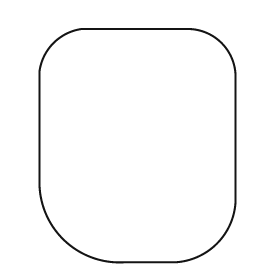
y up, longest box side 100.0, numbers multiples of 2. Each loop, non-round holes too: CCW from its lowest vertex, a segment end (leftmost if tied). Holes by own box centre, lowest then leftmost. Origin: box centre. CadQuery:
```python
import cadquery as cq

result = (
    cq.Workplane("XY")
    .moveTo(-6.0, -50.0)
    .lineTo(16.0, -50.0)
    .threePointArc((34.0, -42.0), (42.0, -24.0))
    .lineTo(42.0, 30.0)
    .threePointArc((36.0, 44.0), (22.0, 50.0))
    .lineTo(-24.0, 50.0)
    .threePointArc((-36.0, 44.0), (-42.0, 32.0))
    .lineTo(-42.0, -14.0)
    .threePointArc((-32.0, -40.0), (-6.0, -50.0))
    .close()
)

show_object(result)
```